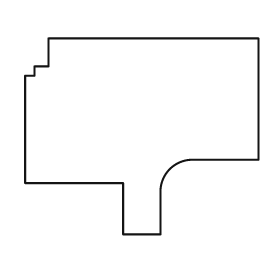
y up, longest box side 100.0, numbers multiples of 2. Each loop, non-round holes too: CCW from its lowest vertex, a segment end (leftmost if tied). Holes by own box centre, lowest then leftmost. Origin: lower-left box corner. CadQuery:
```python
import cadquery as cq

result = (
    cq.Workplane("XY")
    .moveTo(42.0, 0.0)
    .lineTo(58.0, 0.0)
    .lineTo(58.0, 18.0)
    .threePointArc((62.0, 28.0), (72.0, 32.0))
    .lineTo(100.0, 32.0)
    .lineTo(100.0, 84.0)
    .lineTo(10.0, 84.0)
    .lineTo(10.0, 72.0)
    .lineTo(4.0, 72.0)
    .lineTo(4.0, 68.0)
    .lineTo(0.0, 68.0)
    .lineTo(0.0, 22.0)
    .lineTo(42.0, 22.0)
    .close()
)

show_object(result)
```